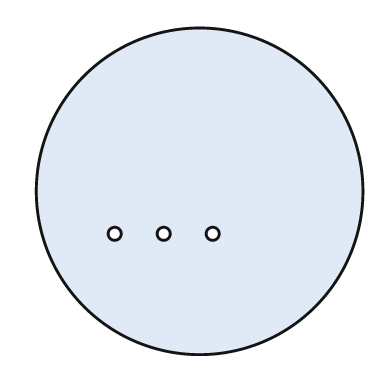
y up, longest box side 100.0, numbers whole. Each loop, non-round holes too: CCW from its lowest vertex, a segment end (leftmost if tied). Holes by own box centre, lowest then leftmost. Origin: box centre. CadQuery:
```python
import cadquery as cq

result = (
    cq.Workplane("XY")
    .moveTo(0.0, 0.0)
    .circle(50.0)
    .moveTo(-26.0, -13.0)
    .circle(2.0)
    .moveTo(-11.0, -13.0)
    .circle(2.0)
    .moveTo(4.0, -13.0)
    .circle(2.0)
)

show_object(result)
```